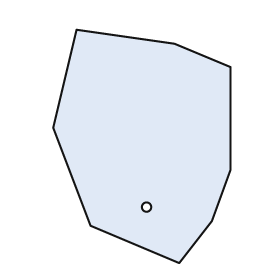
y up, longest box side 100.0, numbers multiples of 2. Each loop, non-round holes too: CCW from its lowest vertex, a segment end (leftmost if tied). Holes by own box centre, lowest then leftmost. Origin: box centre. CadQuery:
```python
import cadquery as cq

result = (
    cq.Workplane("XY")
    .moveTo(16.0, -50.0)
    .lineTo(30.0, -32.0)
    .lineTo(38.0, -10.0)
    .lineTo(38.0, 34.0)
    .lineTo(14.0, 44.0)
    .lineTo(-28.0, 50.0)
    .lineTo(-38.0, 8.0)
    .lineTo(-22.0, -34.0)
    .close()
    .moveTo(2.0, -26.0)
    .circle(2.0)
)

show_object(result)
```